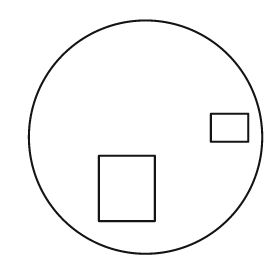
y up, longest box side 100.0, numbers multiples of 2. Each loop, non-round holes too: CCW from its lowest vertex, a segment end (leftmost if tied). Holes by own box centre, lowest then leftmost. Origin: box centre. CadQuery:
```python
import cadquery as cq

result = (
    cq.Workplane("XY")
    .moveTo(0.0, 0.0)
    .circle(50.0)
    .moveTo(-20.0, -36.0)
    .lineTo(4.0, -36.0)
    .lineTo(4.0, -8.0)
    .lineTo(-20.0, -8.0)
    .close()
    .moveTo(28.0, -2.0)
    .lineTo(44.0, -2.0)
    .lineTo(44.0, 10.0)
    .lineTo(28.0, 10.0)
    .close()
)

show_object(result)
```